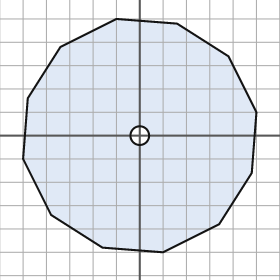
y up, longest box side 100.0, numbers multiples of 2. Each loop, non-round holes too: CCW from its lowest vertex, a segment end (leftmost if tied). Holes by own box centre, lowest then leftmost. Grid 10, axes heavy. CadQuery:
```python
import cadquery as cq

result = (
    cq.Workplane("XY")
    .moveTo(10.0, -50.0)
    .lineTo(34.0, -38.0)
    .lineTo(48.0, -16.0)
    .lineTo(50.0, 10.0)
    .lineTo(38.0, 34.0)
    .lineTo(16.0, 48.0)
    .lineTo(-10.0, 50.0)
    .lineTo(-34.0, 38.0)
    .lineTo(-48.0, 16.0)
    .lineTo(-50.0, -10.0)
    .lineTo(-38.0, -34.0)
    .lineTo(-16.0, -48.0)
    .close()
    .moveTo(0.0, 0.0)
    .circle(4.0)
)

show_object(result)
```